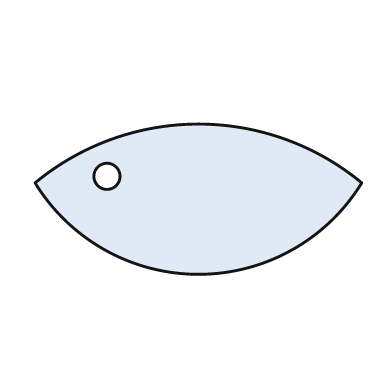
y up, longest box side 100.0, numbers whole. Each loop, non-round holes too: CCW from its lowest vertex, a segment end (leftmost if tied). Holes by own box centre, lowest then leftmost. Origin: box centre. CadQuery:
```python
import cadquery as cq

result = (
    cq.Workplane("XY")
    .moveTo(-50.0, 5.0)
    .threePointArc((0.0, -23.0), (50.0, 5.0))
    .threePointArc((0.0, 23.0), (-50.0, 5.0))
    .close()
    .moveTo(-28.0, 7.0)
    .circle(4.0)
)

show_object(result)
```